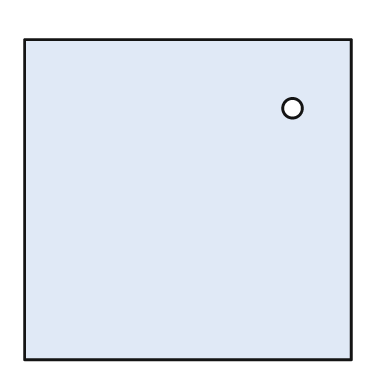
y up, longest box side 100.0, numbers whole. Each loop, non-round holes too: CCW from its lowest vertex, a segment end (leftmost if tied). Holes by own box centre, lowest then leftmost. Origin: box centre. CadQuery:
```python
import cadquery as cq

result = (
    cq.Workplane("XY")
    .moveTo(-50.0, -49.0)
    .lineTo(50.0, -49.0)
    .lineTo(50.0, 49.0)
    .lineTo(-50.0, 49.0)
    .close()
    .moveTo(32.0, 28.0)
    .circle(3.0)
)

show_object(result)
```